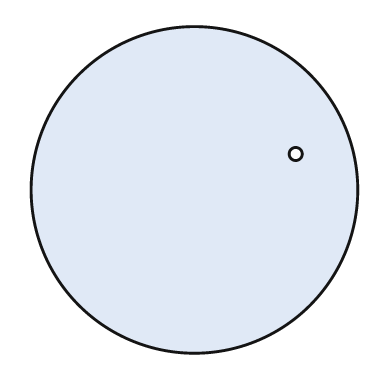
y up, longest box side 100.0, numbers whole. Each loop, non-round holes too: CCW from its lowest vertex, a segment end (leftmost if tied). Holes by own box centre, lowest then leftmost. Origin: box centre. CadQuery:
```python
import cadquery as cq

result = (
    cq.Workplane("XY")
    .moveTo(0.0, 0.0)
    .circle(50.0)
    .moveTo(31.0, 11.0)
    .circle(2.0)
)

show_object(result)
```